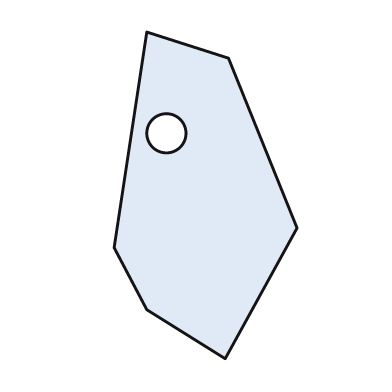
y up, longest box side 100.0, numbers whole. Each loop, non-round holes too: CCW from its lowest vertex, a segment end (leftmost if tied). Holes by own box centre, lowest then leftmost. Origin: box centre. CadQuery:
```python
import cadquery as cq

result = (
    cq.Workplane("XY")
    .moveTo(6.0, -50.0)
    .lineTo(28.0, -10.0)
    .lineTo(7.0, 42.0)
    .lineTo(-18.0, 50.0)
    .lineTo(-28.0, -16.0)
    .lineTo(-18.0, -35.0)
    .close()
    .moveTo(-12.0, 19.0)
    .circle(6.0)
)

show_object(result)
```